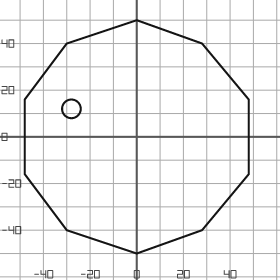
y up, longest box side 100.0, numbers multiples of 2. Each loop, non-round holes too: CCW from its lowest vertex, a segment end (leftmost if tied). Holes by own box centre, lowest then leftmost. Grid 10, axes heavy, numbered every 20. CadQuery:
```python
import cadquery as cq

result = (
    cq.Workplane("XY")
    .moveTo(0.0, -50.0)
    .lineTo(28.0, -40.0)
    .lineTo(48.0, -16.0)
    .lineTo(48.0, 16.0)
    .lineTo(28.0, 40.0)
    .lineTo(0.0, 50.0)
    .lineTo(-30.0, 40.0)
    .lineTo(-48.0, 16.0)
    .lineTo(-48.0, -16.0)
    .lineTo(-30.0, -40.0)
    .close()
    .moveTo(-28.0, 12.0)
    .circle(4.0)
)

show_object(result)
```